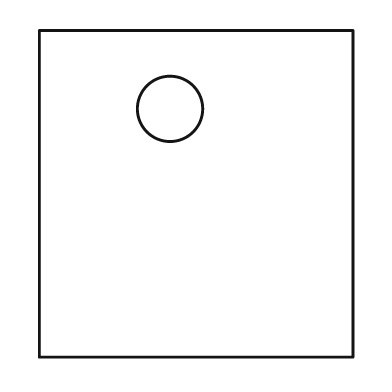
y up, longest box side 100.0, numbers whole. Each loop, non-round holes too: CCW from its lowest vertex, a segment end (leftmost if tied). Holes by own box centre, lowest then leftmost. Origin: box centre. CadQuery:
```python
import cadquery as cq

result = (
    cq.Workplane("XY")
    .moveTo(-48.0, -50.0)
    .lineTo(48.0, -50.0)
    .lineTo(48.0, 50.0)
    .lineTo(-48.0, 50.0)
    .close()
    .moveTo(-8.0, 26.0)
    .circle(10.0)
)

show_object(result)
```